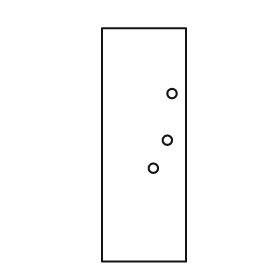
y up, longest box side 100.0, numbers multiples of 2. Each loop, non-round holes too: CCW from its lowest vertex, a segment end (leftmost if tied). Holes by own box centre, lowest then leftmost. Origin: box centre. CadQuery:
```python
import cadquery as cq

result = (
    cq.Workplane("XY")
    .moveTo(-18.0, -50.0)
    .lineTo(18.0, -50.0)
    .lineTo(18.0, 50.0)
    .lineTo(-18.0, 50.0)
    .close()
    .moveTo(4.0, -10.0)
    .circle(2.0)
    .moveTo(10.0, 2.0)
    .circle(2.0)
    .moveTo(12.0, 22.0)
    .circle(2.0)
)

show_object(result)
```